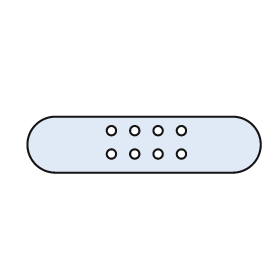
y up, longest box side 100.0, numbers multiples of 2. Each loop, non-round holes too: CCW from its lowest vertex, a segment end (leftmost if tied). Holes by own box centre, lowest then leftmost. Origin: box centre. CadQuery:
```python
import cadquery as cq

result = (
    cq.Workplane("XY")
    .moveTo(-38.0, -12.0)
    .lineTo(38.0, -12.0)
    .threePointArc((50.0, 0.0), (38.0, 12.0))
    .lineTo(-38.0, 12.0)
    .threePointArc((-50.0, 0.0), (-38.0, -12.0))
    .close()
    .moveTo(-14.0, -4.0)
    .circle(2.0)
    .moveTo(-4.0, -4.0)
    .circle(2.0)
    .moveTo(6.0, -4.0)
    .circle(2.0)
    .moveTo(16.0, -4.0)
    .circle(2.0)
    .moveTo(-14.0, 6.0)
    .circle(2.0)
    .moveTo(-4.0, 6.0)
    .circle(2.0)
    .moveTo(6.0, 6.0)
    .circle(2.0)
    .moveTo(16.0, 6.0)
    .circle(2.0)
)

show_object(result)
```